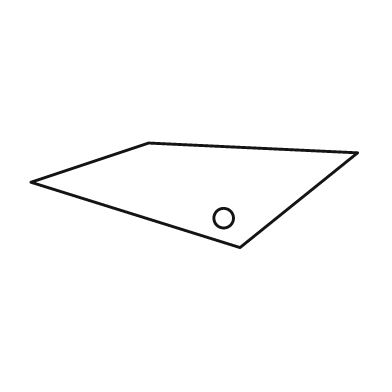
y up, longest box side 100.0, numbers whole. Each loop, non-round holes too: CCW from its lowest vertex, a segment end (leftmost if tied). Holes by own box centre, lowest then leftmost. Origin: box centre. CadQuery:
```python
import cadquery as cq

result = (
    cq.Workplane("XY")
    .moveTo(14.0, -16.0)
    .lineTo(50.0, 13.0)
    .lineTo(-14.0, 16.0)
    .lineTo(-50.0, 4.0)
    .close()
    .moveTo(9.0, -7.0)
    .circle(3.0)
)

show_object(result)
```